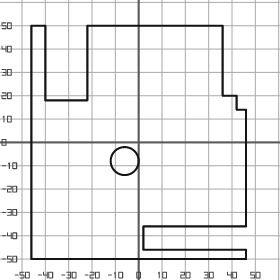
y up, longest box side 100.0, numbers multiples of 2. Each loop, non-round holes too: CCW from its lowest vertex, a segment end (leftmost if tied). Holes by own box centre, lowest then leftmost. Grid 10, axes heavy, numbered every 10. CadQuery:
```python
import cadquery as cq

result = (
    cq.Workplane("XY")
    .moveTo(-46.0, -50.0)
    .lineTo(46.0, -50.0)
    .lineTo(46.0, -46.0)
    .lineTo(2.0, -46.0)
    .lineTo(2.0, -36.0)
    .lineTo(46.0, -36.0)
    .lineTo(46.0, 14.0)
    .lineTo(42.0, 14.0)
    .lineTo(42.0, 20.0)
    .lineTo(36.0, 20.0)
    .lineTo(36.0, 50.0)
    .lineTo(-22.0, 50.0)
    .lineTo(-22.0, 18.0)
    .lineTo(-40.0, 18.0)
    .lineTo(-40.0, 50.0)
    .lineTo(-46.0, 50.0)
    .close()
    .moveTo(-6.0, -8.0)
    .circle(6.0)
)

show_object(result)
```